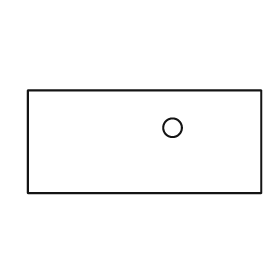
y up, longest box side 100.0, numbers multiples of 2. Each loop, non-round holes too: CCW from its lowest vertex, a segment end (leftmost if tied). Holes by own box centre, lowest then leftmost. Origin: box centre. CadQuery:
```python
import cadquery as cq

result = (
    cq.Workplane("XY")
    .moveTo(-50.0, -22.0)
    .lineTo(50.0, -22.0)
    .lineTo(50.0, 22.0)
    .lineTo(-50.0, 22.0)
    .close()
    .moveTo(12.0, 6.0)
    .circle(4.0)
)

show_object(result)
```